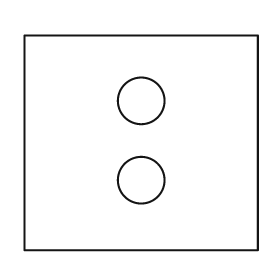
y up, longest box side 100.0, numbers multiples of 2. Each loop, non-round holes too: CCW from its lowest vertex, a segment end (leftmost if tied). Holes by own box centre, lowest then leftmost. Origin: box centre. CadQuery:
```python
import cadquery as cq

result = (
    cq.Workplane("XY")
    .moveTo(-50.0, -46.0)
    .lineTo(50.0, -46.0)
    .lineTo(50.0, 46.0)
    .lineTo(-50.0, 46.0)
    .close()
    .moveTo(0.0, -16.0)
    .circle(10.0)
    .moveTo(0.0, 18.0)
    .circle(10.0)
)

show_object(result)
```